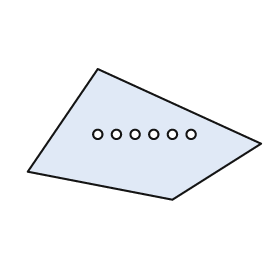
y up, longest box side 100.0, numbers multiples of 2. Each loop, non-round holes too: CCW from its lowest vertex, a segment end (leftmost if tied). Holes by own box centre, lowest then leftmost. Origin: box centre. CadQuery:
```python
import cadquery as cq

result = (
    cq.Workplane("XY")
    .moveTo(12.0, -28.0)
    .lineTo(50.0, -4.0)
    .lineTo(-20.0, 28.0)
    .lineTo(-50.0, -16.0)
    .close()
    .moveTo(-20.0, 0.0)
    .circle(2.0)
    .moveTo(-12.0, 0.0)
    .circle(2.0)
    .moveTo(-4.0, 0.0)
    .circle(2.0)
    .moveTo(4.0, 0.0)
    .circle(2.0)
    .moveTo(12.0, 0.0)
    .circle(2.0)
    .moveTo(20.0, 0.0)
    .circle(2.0)
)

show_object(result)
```